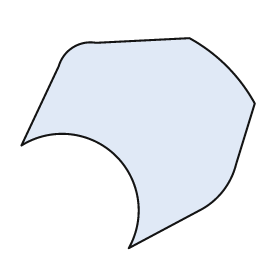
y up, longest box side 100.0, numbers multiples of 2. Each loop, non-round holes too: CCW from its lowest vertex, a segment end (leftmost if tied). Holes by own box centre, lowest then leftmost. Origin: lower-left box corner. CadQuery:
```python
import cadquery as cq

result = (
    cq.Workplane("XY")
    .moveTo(46.0, 0.0)
    .lineTo(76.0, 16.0)
    .threePointArc((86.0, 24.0), (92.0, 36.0))
    .lineTo(100.0, 62.0)
    .threePointArc((88.0, 78.0), (72.0, 90.0))
    .lineTo(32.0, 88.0)
    .threePointArc((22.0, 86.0), (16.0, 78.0))
    .lineTo(0.0, 44.0)
    .threePointArc((40.0, 40.0), (46.0, 0.0))
    .close()
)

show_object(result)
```